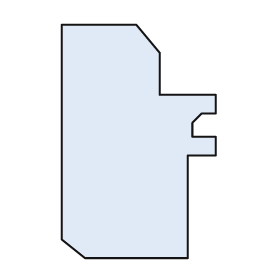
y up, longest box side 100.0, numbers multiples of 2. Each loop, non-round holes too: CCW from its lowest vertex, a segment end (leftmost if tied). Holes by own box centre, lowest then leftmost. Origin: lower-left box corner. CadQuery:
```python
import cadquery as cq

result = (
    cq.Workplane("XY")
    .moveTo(10.0, 0.0)
    .lineTo(54.0, 0.0)
    .lineTo(54.0, 44.0)
    .lineTo(66.0, 44.0)
    .lineTo(66.0, 52.0)
    .lineTo(56.0, 52.0)
    .lineTo(56.0, 58.0)
    .lineTo(60.0, 62.0)
    .lineTo(66.0, 62.0)
    .lineTo(66.0, 70.0)
    .lineTo(42.0, 70.0)
    .lineTo(42.0, 88.0)
    .lineTo(32.0, 100.0)
    .lineTo(0.0, 100.0)
    .lineTo(0.0, 8.0)
    .close()
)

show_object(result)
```